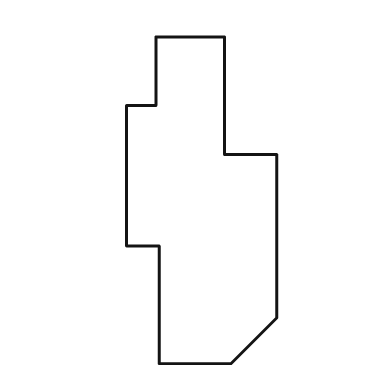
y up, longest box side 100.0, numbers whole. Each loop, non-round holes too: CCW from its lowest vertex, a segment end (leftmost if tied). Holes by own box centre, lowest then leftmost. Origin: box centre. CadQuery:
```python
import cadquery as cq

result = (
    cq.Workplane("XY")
    .moveTo(-13.0, -50.0)
    .lineTo(9.0, -50.0)
    .lineTo(23.0, -36.0)
    .lineTo(23.0, 14.0)
    .lineTo(7.0, 14.0)
    .lineTo(7.0, 50.0)
    .lineTo(-14.0, 50.0)
    .lineTo(-14.0, 29.0)
    .lineTo(-23.0, 29.0)
    .lineTo(-23.0, -14.0)
    .lineTo(-13.0, -14.0)
    .close()
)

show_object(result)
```